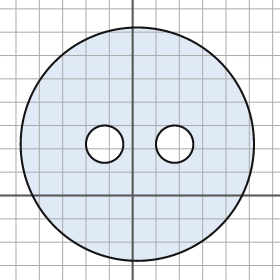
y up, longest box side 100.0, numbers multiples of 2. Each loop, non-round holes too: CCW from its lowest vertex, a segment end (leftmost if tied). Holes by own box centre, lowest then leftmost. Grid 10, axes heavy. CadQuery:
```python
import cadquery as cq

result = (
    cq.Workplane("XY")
    .moveTo(2.0, 22.0)
    .circle(50.0)
    .moveTo(-12.0, 22.0)
    .circle(8.0)
    .moveTo(18.0, 22.0)
    .circle(8.0)
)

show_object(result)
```